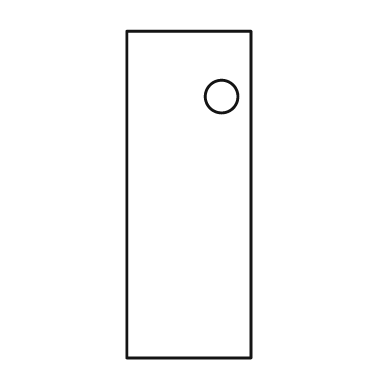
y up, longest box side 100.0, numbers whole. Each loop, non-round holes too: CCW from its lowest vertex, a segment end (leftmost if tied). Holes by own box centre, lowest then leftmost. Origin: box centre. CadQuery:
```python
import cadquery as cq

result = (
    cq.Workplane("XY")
    .moveTo(-19.0, -50.0)
    .lineTo(19.0, -50.0)
    .lineTo(19.0, 50.0)
    .lineTo(-19.0, 50.0)
    .close()
    .moveTo(10.0, 30.0)
    .circle(5.0)
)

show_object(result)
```